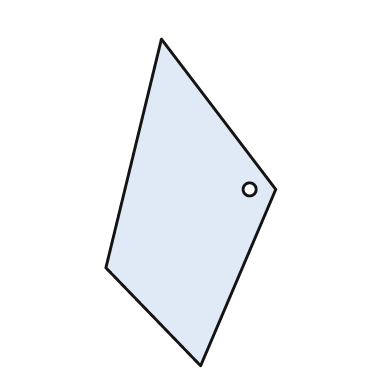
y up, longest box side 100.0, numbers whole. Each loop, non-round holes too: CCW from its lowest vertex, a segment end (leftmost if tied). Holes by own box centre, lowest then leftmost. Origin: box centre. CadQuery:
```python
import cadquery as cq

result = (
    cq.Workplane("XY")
    .moveTo(3.0, -50.0)
    .lineTo(26.0, 4.0)
    .lineTo(-9.0, 50.0)
    .lineTo(-26.0, -20.0)
    .close()
    .moveTo(18.0, 4.0)
    .circle(2.0)
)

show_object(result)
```